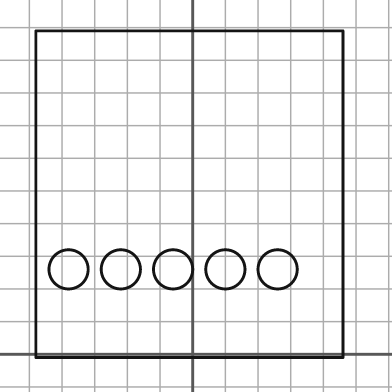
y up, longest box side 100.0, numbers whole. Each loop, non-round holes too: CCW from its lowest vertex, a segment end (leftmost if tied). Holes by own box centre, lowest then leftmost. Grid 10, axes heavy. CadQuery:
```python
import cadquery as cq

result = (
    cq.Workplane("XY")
    .moveTo(-48.0, -1.0)
    .lineTo(46.0, -1.0)
    .lineTo(46.0, 99.0)
    .lineTo(-48.0, 99.0)
    .close()
    .moveTo(-38.0, 26.0)
    .circle(6.0)
    .moveTo(-22.0, 26.0)
    .circle(6.0)
    .moveTo(-6.0, 26.0)
    .circle(6.0)
    .moveTo(10.0, 26.0)
    .circle(6.0)
    .moveTo(26.0, 26.0)
    .circle(6.0)
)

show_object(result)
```